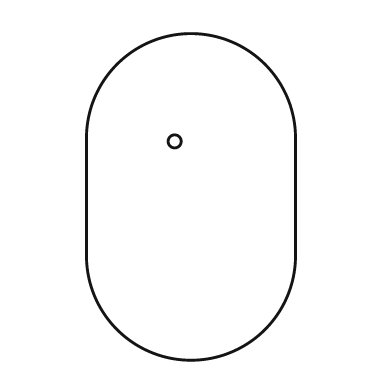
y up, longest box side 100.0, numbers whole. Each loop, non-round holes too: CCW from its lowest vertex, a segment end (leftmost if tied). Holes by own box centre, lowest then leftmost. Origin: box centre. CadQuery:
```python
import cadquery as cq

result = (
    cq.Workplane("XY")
    .moveTo(-32.0, -18.0)
    .threePointArc((0.0, -50.0), (32.0, -18.0))
    .lineTo(32.0, 18.0)
    .threePointArc((0.0, 50.0), (-32.0, 18.0))
    .close()
    .moveTo(-5.0, 17.0)
    .circle(2.0)
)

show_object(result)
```